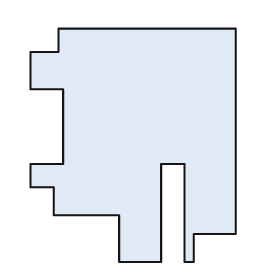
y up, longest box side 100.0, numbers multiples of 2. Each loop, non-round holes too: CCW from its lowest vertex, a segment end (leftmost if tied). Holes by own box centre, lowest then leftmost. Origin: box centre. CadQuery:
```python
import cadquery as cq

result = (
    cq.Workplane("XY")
    .moveTo(-6.0, -50.0)
    .lineTo(12.0, -50.0)
    .lineTo(12.0, -8.0)
    .lineTo(22.0, -8.0)
    .lineTo(22.0, -50.0)
    .lineTo(26.0, -50.0)
    .lineTo(26.0, -38.0)
    .lineTo(44.0, -38.0)
    .lineTo(44.0, 50.0)
    .lineTo(-32.0, 50.0)
    .lineTo(-32.0, 40.0)
    .lineTo(-44.0, 40.0)
    .lineTo(-44.0, 24.0)
    .lineTo(-30.0, 24.0)
    .lineTo(-30.0, -8.0)
    .lineTo(-44.0, -8.0)
    .lineTo(-44.0, -18.0)
    .lineTo(-34.0, -18.0)
    .lineTo(-34.0, -30.0)
    .lineTo(-6.0, -30.0)
    .close()
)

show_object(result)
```